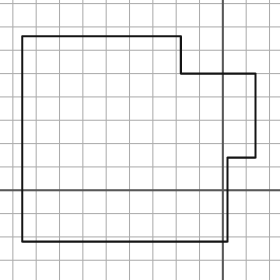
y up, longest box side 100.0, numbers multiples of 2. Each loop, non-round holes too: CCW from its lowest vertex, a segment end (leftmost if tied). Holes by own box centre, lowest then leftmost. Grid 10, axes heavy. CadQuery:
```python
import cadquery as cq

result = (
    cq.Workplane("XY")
    .moveTo(-86.0, -22.0)
    .lineTo(2.0, -22.0)
    .lineTo(2.0, 14.0)
    .lineTo(14.0, 14.0)
    .lineTo(14.0, 50.0)
    .lineTo(-18.0, 50.0)
    .lineTo(-18.0, 66.0)
    .lineTo(-86.0, 66.0)
    .close()
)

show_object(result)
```